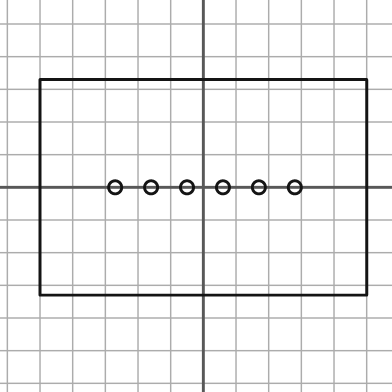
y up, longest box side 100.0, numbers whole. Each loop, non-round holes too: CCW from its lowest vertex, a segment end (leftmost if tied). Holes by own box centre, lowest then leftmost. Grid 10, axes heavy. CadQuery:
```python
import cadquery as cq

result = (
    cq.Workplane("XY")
    .moveTo(-50.0, -33.0)
    .lineTo(50.0, -33.0)
    .lineTo(50.0, 33.0)
    .lineTo(-50.0, 33.0)
    .close()
    .moveTo(-27.0, 0.0)
    .circle(2.0)
    .moveTo(-16.0, 0.0)
    .circle(2.0)
    .moveTo(-5.0, 0.0)
    .circle(2.0)
    .moveTo(6.0, 0.0)
    .circle(2.0)
    .moveTo(17.0, 0.0)
    .circle(2.0)
    .moveTo(28.0, 0.0)
    .circle(2.0)
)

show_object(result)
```